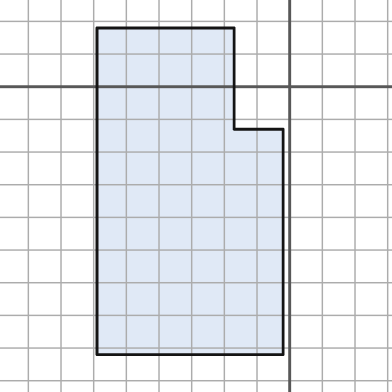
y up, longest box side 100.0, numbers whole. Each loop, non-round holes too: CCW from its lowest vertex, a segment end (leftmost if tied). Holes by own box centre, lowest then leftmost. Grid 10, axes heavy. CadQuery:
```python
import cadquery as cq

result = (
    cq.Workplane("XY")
    .moveTo(-59.0, -82.0)
    .lineTo(-2.0, -82.0)
    .lineTo(-2.0, -13.0)
    .lineTo(-17.0, -13.0)
    .lineTo(-17.0, 18.0)
    .lineTo(-59.0, 18.0)
    .close()
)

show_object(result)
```